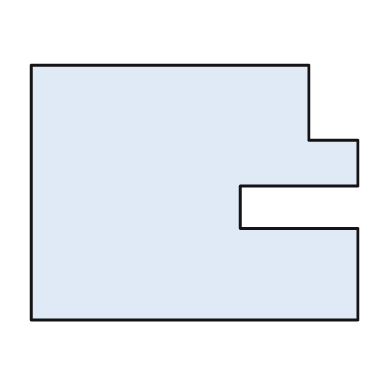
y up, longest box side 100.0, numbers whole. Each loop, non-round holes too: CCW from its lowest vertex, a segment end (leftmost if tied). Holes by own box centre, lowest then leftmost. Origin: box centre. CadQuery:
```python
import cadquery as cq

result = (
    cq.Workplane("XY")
    .moveTo(-50.0, -39.0)
    .lineTo(50.0, -39.0)
    .lineTo(50.0, -11.0)
    .lineTo(14.0, -11.0)
    .lineTo(14.0, 2.0)
    .lineTo(50.0, 2.0)
    .lineTo(50.0, 16.0)
    .lineTo(35.0, 16.0)
    .lineTo(35.0, 39.0)
    .lineTo(-50.0, 39.0)
    .close()
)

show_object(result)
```